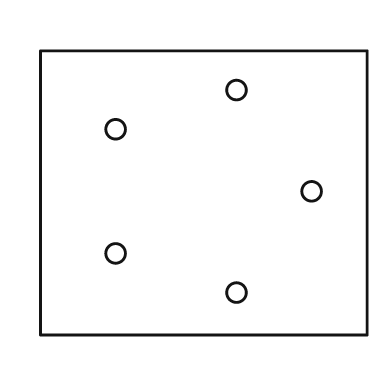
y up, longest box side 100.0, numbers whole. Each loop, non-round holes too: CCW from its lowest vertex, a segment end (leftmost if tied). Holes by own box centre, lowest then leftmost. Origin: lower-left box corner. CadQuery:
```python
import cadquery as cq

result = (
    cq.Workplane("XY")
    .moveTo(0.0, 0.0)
    .lineTo(100.0, 0.0)
    .lineTo(100.0, 87.0)
    .lineTo(0.0, 87.0)
    .close()
    .moveTo(60.0, 13.0)
    .circle(3.0)
    .moveTo(23.0, 25.0)
    .circle(3.0)
    .moveTo(83.0, 44.0)
    .circle(3.0)
    .moveTo(23.0, 63.0)
    .circle(3.0)
    .moveTo(60.0, 75.0)
    .circle(3.0)
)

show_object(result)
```